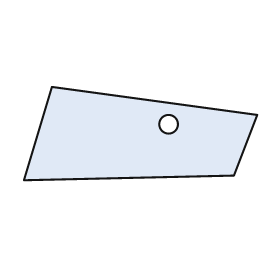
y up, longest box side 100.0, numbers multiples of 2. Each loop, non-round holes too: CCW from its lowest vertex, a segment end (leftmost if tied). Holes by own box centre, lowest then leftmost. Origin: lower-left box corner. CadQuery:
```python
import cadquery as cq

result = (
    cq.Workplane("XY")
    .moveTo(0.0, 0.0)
    .lineTo(90.0, 2.0)
    .lineTo(100.0, 28.0)
    .lineTo(12.0, 40.0)
    .close()
    .moveTo(62.0, 24.0)
    .circle(4.0)
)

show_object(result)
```